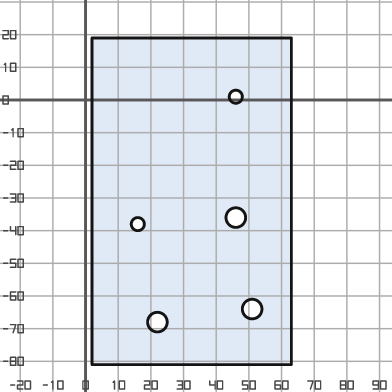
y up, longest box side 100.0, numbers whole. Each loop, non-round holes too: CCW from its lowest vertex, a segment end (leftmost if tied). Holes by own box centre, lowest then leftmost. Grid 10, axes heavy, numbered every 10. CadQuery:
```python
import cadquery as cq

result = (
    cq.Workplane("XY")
    .moveTo(2.0, -81.0)
    .lineTo(63.0, -81.0)
    .lineTo(63.0, 19.0)
    .lineTo(2.0, 19.0)
    .close()
    .moveTo(22.0, -68.0)
    .circle(3.0)
    .moveTo(51.0, -64.0)
    .circle(3.0)
    .moveTo(16.0, -38.0)
    .circle(2.0)
    .moveTo(46.0, -36.0)
    .circle(3.0)
    .moveTo(46.0, 1.0)
    .circle(2.0)
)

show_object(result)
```